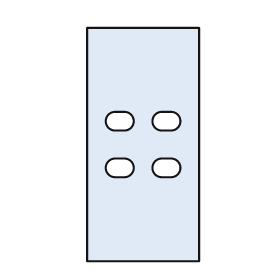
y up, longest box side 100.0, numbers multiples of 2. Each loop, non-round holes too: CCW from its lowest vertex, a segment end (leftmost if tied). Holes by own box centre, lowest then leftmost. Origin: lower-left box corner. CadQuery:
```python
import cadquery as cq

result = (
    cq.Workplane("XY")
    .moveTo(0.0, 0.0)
    .lineTo(48.0, 0.0)
    .lineTo(48.0, 100.0)
    .lineTo(0.0, 100.0)
    .close()
    .moveTo(12.0, 36.0)
    .lineTo(16.0, 36.0)
    .threePointArc((20.0, 40.0), (16.0, 44.0))
    .lineTo(12.0, 44.0)
    .threePointArc((8.0, 40.0), (12.0, 36.0))
    .close()
    .moveTo(32.0, 36.0)
    .lineTo(36.0, 36.0)
    .threePointArc((40.0, 40.0), (36.0, 44.0))
    .lineTo(32.0, 44.0)
    .threePointArc((28.0, 40.0), (32.0, 36.0))
    .close()
    .moveTo(12.0, 56.0)
    .lineTo(16.0, 56.0)
    .threePointArc((20.0, 60.0), (16.0, 64.0))
    .lineTo(12.0, 64.0)
    .threePointArc((8.0, 60.0), (12.0, 56.0))
    .close()
    .moveTo(32.0, 56.0)
    .lineTo(36.0, 56.0)
    .threePointArc((40.0, 60.0), (36.0, 64.0))
    .lineTo(32.0, 64.0)
    .threePointArc((28.0, 60.0), (32.0, 56.0))
    .close()
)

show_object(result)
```